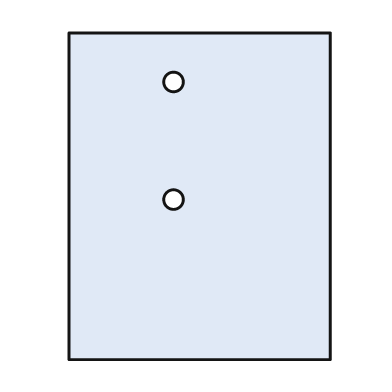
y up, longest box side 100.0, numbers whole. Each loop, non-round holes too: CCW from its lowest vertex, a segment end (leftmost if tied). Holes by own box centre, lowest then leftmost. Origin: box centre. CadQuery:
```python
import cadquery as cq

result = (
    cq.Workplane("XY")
    .moveTo(-40.0, -50.0)
    .lineTo(40.0, -50.0)
    .lineTo(40.0, 50.0)
    .lineTo(-40.0, 50.0)
    .close()
    .moveTo(-8.0, -1.0)
    .circle(3.0)
    .moveTo(-8.0, 35.0)
    .circle(3.0)
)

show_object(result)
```